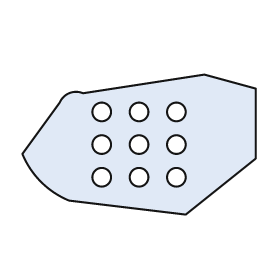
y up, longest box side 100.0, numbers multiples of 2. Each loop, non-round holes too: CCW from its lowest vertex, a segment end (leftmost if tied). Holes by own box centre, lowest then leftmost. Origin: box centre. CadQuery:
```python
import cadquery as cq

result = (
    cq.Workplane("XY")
    .moveTo(20.0, -30.0)
    .lineTo(50.0, -6.0)
    .lineTo(50.0, 24.0)
    .lineTo(28.0, 30.0)
    .lineTo(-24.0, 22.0)
    .threePointArc((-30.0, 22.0), (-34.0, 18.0))
    .lineTo(-50.0, -4.0)
    .threePointArc((-42.0, -16.0), (-30.0, -24.0))
    .close()
    .moveTo(-16.0, -14.0)
    .circle(4.0)
    .moveTo(0.0, -14.0)
    .circle(4.0)
    .moveTo(16.0, -14.0)
    .circle(4.0)
    .moveTo(-16.0, 0.0)
    .circle(4.0)
    .moveTo(0.0, 0.0)
    .circle(4.0)
    .moveTo(16.0, 0.0)
    .circle(4.0)
    .moveTo(-16.0, 14.0)
    .circle(4.0)
    .moveTo(0.0, 14.0)
    .circle(4.0)
    .moveTo(16.0, 14.0)
    .circle(4.0)
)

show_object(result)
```